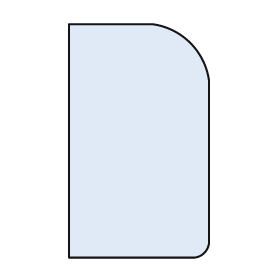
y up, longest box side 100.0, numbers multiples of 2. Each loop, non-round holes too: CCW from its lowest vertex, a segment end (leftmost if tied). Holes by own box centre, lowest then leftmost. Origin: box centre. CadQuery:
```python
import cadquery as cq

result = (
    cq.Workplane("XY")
    .moveTo(-30.0, -50.0)
    .lineTo(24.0, -50.0)
    .threePointArc((28.0, -48.0), (30.0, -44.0))
    .lineTo(30.0, 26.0)
    .threePointArc((22.0, 42.0), (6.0, 50.0))
    .lineTo(-30.0, 50.0)
    .close()
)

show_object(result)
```